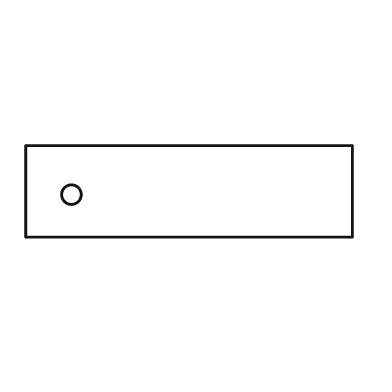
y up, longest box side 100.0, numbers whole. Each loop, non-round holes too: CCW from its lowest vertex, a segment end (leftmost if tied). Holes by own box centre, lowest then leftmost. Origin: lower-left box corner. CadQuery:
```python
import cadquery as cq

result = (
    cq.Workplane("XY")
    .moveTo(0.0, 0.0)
    .lineTo(100.0, 0.0)
    .lineTo(100.0, 28.0)
    .lineTo(0.0, 28.0)
    .close()
    .moveTo(14.0, 13.0)
    .circle(3.0)
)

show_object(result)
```